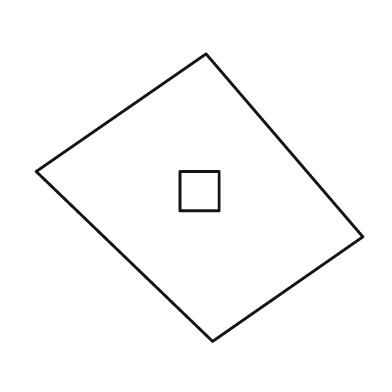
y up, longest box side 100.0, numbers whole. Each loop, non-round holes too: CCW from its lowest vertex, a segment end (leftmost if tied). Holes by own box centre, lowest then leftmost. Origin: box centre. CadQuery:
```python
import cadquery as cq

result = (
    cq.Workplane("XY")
    .moveTo(4.0, -44.0)
    .lineTo(50.0, -12.0)
    .lineTo(2.0, 44.0)
    .lineTo(-50.0, 8.0)
    .close()
    .moveTo(-6.0, -4.0)
    .lineTo(6.0, -4.0)
    .lineTo(6.0, 8.0)
    .lineTo(-6.0, 8.0)
    .close()
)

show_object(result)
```